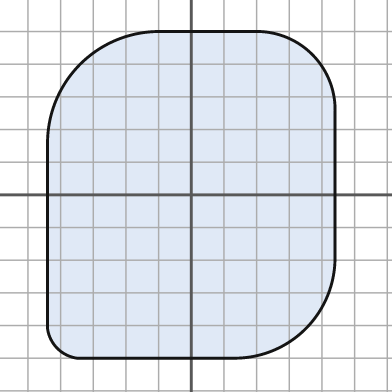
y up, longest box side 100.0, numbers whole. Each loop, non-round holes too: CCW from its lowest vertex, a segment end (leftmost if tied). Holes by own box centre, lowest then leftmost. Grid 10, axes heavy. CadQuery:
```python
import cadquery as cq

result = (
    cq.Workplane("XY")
    .moveTo(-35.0, -50.0)
    .lineTo(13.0, -50.0)
    .threePointArc((35.0, -41.0), (44.0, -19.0))
    .lineTo(44.0, 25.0)
    .threePointArc((37.0, 43.0), (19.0, 50.0))
    .lineTo(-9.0, 50.0)
    .threePointArc((-34.0, 40.0), (-44.0, 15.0))
    .lineTo(-44.0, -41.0)
    .threePointArc((-41.0, -47.0), (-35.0, -50.0))
    .close()
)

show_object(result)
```